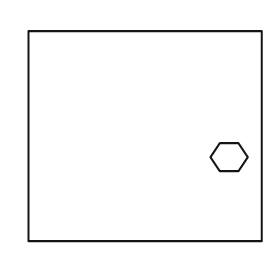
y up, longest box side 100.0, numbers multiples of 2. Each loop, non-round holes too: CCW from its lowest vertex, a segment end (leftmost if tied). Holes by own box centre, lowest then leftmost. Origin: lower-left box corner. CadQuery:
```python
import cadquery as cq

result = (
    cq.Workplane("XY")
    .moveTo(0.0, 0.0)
    .lineTo(100.0, 0.0)
    .lineTo(100.0, 90.0)
    .lineTo(0.0, 90.0)
    .close()
    .moveTo(82.0, 30.0)
    .lineTo(90.0, 30.0)
    .lineTo(94.0, 36.0)
    .lineTo(90.0, 42.0)
    .lineTo(82.0, 42.0)
    .lineTo(78.0, 36.0)
    .close()
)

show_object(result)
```